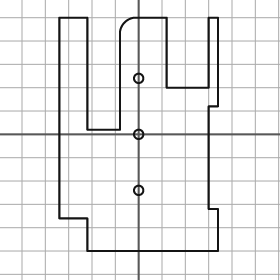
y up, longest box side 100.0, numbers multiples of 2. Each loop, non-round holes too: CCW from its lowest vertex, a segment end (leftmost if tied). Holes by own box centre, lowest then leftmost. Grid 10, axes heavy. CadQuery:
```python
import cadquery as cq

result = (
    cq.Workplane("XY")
    .moveTo(-22.0, -50.0)
    .lineTo(34.0, -50.0)
    .lineTo(34.0, -32.0)
    .lineTo(30.0, -32.0)
    .lineTo(30.0, 12.0)
    .lineTo(34.0, 12.0)
    .lineTo(34.0, 50.0)
    .lineTo(30.0, 50.0)
    .lineTo(30.0, 20.0)
    .lineTo(12.0, 20.0)
    .lineTo(12.0, 50.0)
    .lineTo(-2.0, 50.0)
    .threePointArc((-6.0, 48.0), (-8.0, 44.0))
    .lineTo(-8.0, 2.0)
    .lineTo(-22.0, 2.0)
    .lineTo(-22.0, 50.0)
    .lineTo(-34.0, 50.0)
    .lineTo(-34.0, -36.0)
    .lineTo(-22.0, -36.0)
    .close()
    .moveTo(0.0, -24.0)
    .circle(2.0)
    .moveTo(0.0, 0.0)
    .circle(2.0)
    .moveTo(0.0, 24.0)
    .circle(2.0)
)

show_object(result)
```